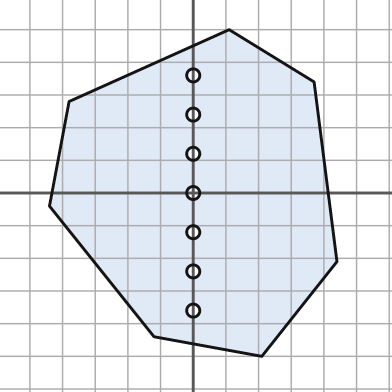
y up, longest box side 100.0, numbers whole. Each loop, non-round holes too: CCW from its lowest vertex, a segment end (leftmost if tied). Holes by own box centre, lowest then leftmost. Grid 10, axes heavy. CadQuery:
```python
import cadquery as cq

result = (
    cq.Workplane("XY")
    .moveTo(21.0, -50.0)
    .lineTo(44.0, -21.0)
    .lineTo(37.0, 34.0)
    .lineTo(11.0, 50.0)
    .lineTo(-38.0, 28.0)
    .lineTo(-44.0, -4.0)
    .lineTo(-12.0, -44.0)
    .close()
    .moveTo(0.0, -36.0)
    .circle(2.0)
    .moveTo(0.0, -24.0)
    .circle(2.0)
    .moveTo(0.0, -12.0)
    .circle(2.0)
    .moveTo(0.0, 0.0)
    .circle(2.0)
    .moveTo(0.0, 12.0)
    .circle(2.0)
    .moveTo(0.0, 24.0)
    .circle(2.0)
    .moveTo(0.0, 36.0)
    .circle(2.0)
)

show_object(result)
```